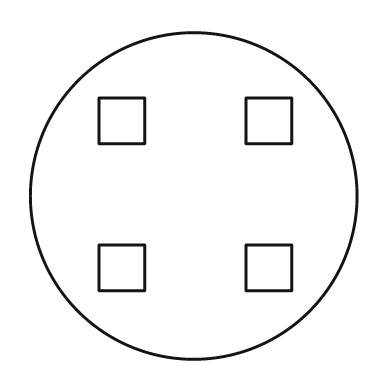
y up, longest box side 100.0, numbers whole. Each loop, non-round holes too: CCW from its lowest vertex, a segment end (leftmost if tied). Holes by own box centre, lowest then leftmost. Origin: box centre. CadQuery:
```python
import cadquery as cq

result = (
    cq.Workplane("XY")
    .moveTo(0.0, 0.0)
    .circle(50.0)
    .moveTo(-29.0, -29.0)
    .lineTo(-15.0, -29.0)
    .lineTo(-15.0, -15.0)
    .lineTo(-29.0, -15.0)
    .close()
    .moveTo(16.0, -29.0)
    .lineTo(30.0, -29.0)
    .lineTo(30.0, -15.0)
    .lineTo(16.0, -15.0)
    .close()
    .moveTo(-29.0, 16.0)
    .lineTo(-15.0, 16.0)
    .lineTo(-15.0, 30.0)
    .lineTo(-29.0, 30.0)
    .close()
    .moveTo(16.0, 16.0)
    .lineTo(30.0, 16.0)
    .lineTo(30.0, 30.0)
    .lineTo(16.0, 30.0)
    .close()
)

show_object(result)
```